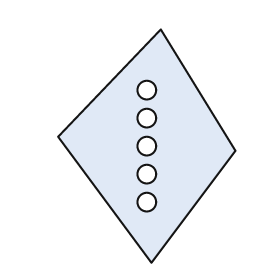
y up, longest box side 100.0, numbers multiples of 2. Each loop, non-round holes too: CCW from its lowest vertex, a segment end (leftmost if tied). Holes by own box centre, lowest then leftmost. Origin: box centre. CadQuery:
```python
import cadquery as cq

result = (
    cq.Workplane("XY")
    .moveTo(2.0, -50.0)
    .lineTo(38.0, -2.0)
    .lineTo(6.0, 50.0)
    .lineTo(-38.0, 4.0)
    .close()
    .moveTo(0.0, -24.0)
    .circle(4.0)
    .moveTo(0.0, -12.0)
    .circle(4.0)
    .moveTo(0.0, 0.0)
    .circle(4.0)
    .moveTo(0.0, 12.0)
    .circle(4.0)
    .moveTo(0.0, 24.0)
    .circle(4.0)
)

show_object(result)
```